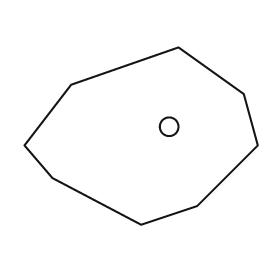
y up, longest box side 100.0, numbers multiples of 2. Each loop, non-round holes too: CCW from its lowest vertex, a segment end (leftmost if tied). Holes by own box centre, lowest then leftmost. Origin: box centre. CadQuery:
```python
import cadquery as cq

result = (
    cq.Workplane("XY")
    .moveTo(0.0, -38.0)
    .lineTo(24.0, -30.0)
    .lineTo(50.0, -4.0)
    .lineTo(44.0, 18.0)
    .lineTo(16.0, 38.0)
    .lineTo(-30.0, 22.0)
    .lineTo(-50.0, -4.0)
    .lineTo(-38.0, -18.0)
    .close()
    .moveTo(12.0, 4.0)
    .circle(4.0)
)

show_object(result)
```